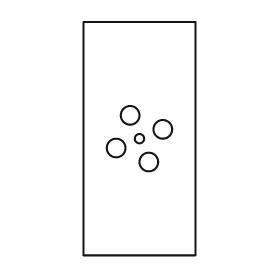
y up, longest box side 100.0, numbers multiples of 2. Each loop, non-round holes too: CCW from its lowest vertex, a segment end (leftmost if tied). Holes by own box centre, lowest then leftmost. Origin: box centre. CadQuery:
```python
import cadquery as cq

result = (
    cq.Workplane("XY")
    .moveTo(-24.0, -50.0)
    .lineTo(24.0, -50.0)
    .lineTo(24.0, 50.0)
    .lineTo(-24.0, 50.0)
    .close()
    .moveTo(4.0, -10.0)
    .circle(4.0)
    .moveTo(-10.0, -4.0)
    .circle(4.0)
    .moveTo(0.0, 0.0)
    .circle(2.0)
    .moveTo(10.0, 4.0)
    .circle(4.0)
    .moveTo(-4.0, 10.0)
    .circle(4.0)
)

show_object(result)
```